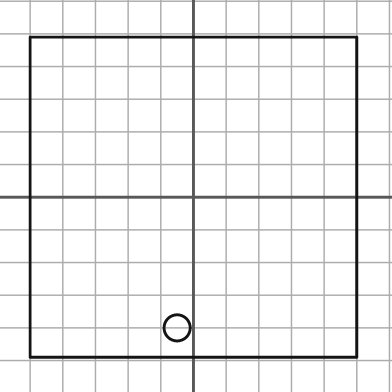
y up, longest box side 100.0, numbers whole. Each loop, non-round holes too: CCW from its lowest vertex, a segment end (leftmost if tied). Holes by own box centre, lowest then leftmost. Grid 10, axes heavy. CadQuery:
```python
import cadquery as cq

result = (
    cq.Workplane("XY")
    .moveTo(-50.0, -49.0)
    .lineTo(50.0, -49.0)
    .lineTo(50.0, 49.0)
    .lineTo(-50.0, 49.0)
    .close()
    .moveTo(-5.0, -40.0)
    .circle(4.0)
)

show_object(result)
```